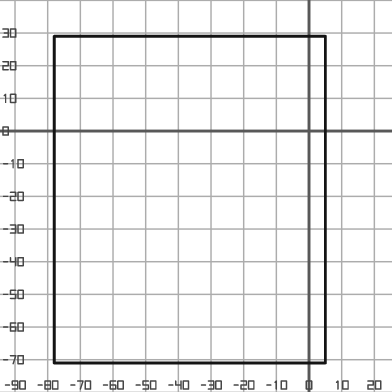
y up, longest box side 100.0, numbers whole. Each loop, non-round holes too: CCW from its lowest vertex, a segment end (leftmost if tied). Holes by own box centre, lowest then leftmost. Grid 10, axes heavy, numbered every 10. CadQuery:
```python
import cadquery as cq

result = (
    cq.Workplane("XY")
    .moveTo(-78.0, -71.0)
    .lineTo(5.0, -71.0)
    .lineTo(5.0, 29.0)
    .lineTo(-78.0, 29.0)
    .close()
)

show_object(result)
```